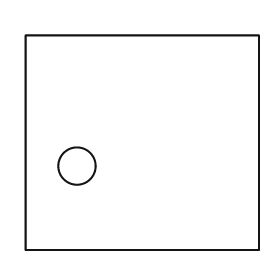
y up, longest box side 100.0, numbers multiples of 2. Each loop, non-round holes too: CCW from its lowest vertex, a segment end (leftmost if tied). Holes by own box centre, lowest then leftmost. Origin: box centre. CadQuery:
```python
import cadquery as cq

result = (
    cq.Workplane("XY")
    .moveTo(-50.0, -46.0)
    .lineTo(50.0, -46.0)
    .lineTo(50.0, 46.0)
    .lineTo(-50.0, 46.0)
    .close()
    .moveTo(-28.0, -10.0)
    .circle(8.0)
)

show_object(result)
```